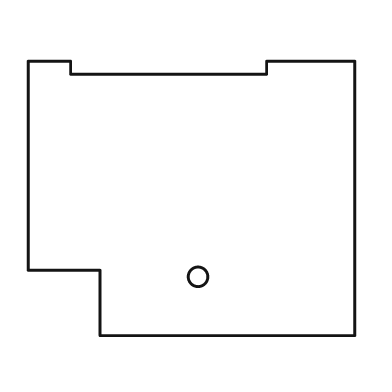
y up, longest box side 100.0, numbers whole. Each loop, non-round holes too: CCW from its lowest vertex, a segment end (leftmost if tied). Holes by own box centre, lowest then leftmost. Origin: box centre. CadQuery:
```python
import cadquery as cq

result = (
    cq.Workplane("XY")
    .moveTo(-28.0, -42.0)
    .lineTo(50.0, -42.0)
    .lineTo(50.0, 42.0)
    .lineTo(23.0, 42.0)
    .lineTo(23.0, 38.0)
    .lineTo(-37.0, 38.0)
    .lineTo(-37.0, 42.0)
    .lineTo(-50.0, 42.0)
    .lineTo(-50.0, -22.0)
    .lineTo(-28.0, -22.0)
    .close()
    .moveTo(2.0, -24.0)
    .circle(3.0)
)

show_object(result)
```